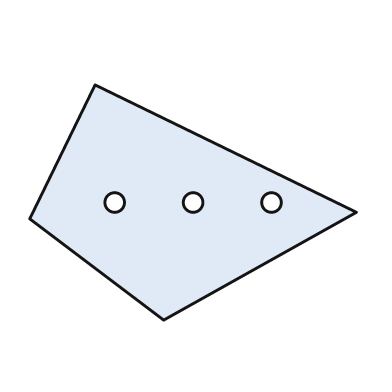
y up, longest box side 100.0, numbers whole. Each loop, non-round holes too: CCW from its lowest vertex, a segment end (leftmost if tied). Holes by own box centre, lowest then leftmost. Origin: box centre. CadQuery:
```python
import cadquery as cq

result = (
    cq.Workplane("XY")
    .moveTo(-9.0, -36.0)
    .lineTo(50.0, -3.0)
    .lineTo(-30.0, 36.0)
    .lineTo(-50.0, -5.0)
    .close()
    .moveTo(-24.0, 0.0)
    .circle(3.0)
    .moveTo(0.0, 0.0)
    .circle(3.0)
    .moveTo(24.0, 0.0)
    .circle(3.0)
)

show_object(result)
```